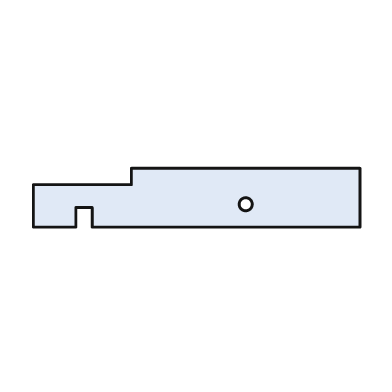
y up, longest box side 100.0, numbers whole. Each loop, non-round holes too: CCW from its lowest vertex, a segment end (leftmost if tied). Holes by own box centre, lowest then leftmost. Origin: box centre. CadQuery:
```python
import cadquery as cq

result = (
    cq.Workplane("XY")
    .moveTo(-50.0, -9.0)
    .lineTo(-37.0, -9.0)
    .lineTo(-37.0, -3.0)
    .lineTo(-32.0, -3.0)
    .lineTo(-32.0, -9.0)
    .lineTo(50.0, -9.0)
    .lineTo(50.0, 9.0)
    .lineTo(-20.0, 9.0)
    .lineTo(-20.0, 4.0)
    .lineTo(-50.0, 4.0)
    .close()
    .moveTo(15.0, -2.0)
    .circle(2.0)
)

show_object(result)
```